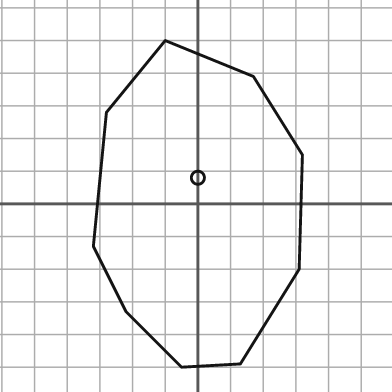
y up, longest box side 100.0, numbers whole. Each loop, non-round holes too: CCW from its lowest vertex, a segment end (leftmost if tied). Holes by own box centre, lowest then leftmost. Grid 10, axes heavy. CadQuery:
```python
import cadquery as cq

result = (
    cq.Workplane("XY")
    .moveTo(-5.0, -50.0)
    .lineTo(13.0, -49.0)
    .lineTo(31.0, -20.0)
    .lineTo(32.0, 15.0)
    .lineTo(17.0, 39.0)
    .lineTo(-10.0, 50.0)
    .lineTo(-28.0, 28.0)
    .lineTo(-32.0, -13.0)
    .lineTo(-22.0, -33.0)
    .close()
    .moveTo(0.0, 8.0)
    .circle(2.0)
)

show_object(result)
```